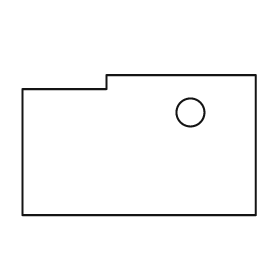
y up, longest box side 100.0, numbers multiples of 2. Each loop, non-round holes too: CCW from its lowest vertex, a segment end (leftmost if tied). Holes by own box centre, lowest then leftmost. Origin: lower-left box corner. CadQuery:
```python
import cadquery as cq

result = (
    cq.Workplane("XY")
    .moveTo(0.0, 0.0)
    .lineTo(100.0, 0.0)
    .lineTo(100.0, 60.0)
    .lineTo(36.0, 60.0)
    .lineTo(36.0, 54.0)
    .lineTo(0.0, 54.0)
    .close()
    .moveTo(72.0, 44.0)
    .circle(6.0)
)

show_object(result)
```